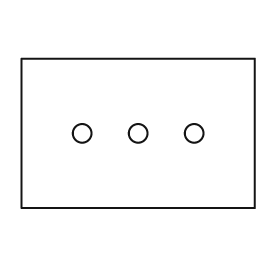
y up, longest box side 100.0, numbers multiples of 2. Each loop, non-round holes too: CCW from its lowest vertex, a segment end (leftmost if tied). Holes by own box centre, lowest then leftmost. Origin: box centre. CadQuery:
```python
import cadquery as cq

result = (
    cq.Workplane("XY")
    .moveTo(-50.0, -32.0)
    .lineTo(50.0, -32.0)
    .lineTo(50.0, 32.0)
    .lineTo(-50.0, 32.0)
    .close()
    .moveTo(-24.0, 0.0)
    .circle(4.0)
    .moveTo(0.0, 0.0)
    .circle(4.0)
    .moveTo(24.0, 0.0)
    .circle(4.0)
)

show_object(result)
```